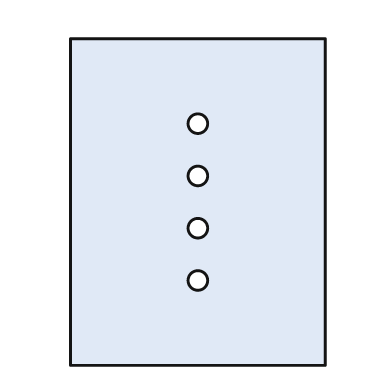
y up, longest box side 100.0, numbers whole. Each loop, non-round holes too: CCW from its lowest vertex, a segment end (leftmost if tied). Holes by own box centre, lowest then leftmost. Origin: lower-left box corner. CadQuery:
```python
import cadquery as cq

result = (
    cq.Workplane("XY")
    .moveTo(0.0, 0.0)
    .lineTo(78.0, 0.0)
    .lineTo(78.0, 100.0)
    .lineTo(0.0, 100.0)
    .close()
    .moveTo(39.0, 26.0)
    .circle(3.0)
    .moveTo(39.0, 42.0)
    .circle(3.0)
    .moveTo(39.0, 58.0)
    .circle(3.0)
    .moveTo(39.0, 74.0)
    .circle(3.0)
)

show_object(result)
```